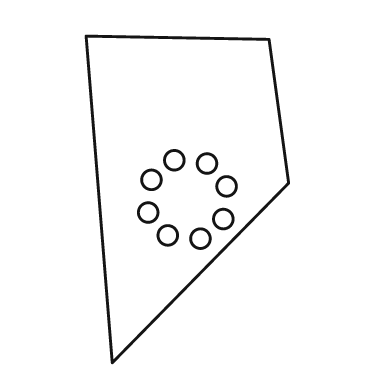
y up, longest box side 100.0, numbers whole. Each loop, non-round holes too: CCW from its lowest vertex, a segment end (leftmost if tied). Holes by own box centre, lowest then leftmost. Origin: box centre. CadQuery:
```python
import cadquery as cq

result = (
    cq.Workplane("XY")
    .moveTo(-23.0, -50.0)
    .lineTo(31.0, 5.0)
    .lineTo(25.0, 49.0)
    .lineTo(-31.0, 50.0)
    .close()
    .moveTo(4.0, -12.0)
    .circle(3.0)
    .moveTo(-6.0, -11.0)
    .circle(3.0)
    .moveTo(11.0, -6.0)
    .circle(3.0)
    .moveTo(-12.0, -4.0)
    .circle(3.0)
    .moveTo(12.0, 4.0)
    .circle(3.0)
    .moveTo(-11.0, 6.0)
    .circle(3.0)
    .moveTo(6.0, 11.0)
    .circle(3.0)
    .moveTo(-4.0, 12.0)
    .circle(3.0)
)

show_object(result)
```